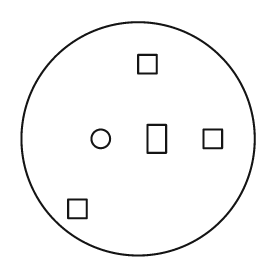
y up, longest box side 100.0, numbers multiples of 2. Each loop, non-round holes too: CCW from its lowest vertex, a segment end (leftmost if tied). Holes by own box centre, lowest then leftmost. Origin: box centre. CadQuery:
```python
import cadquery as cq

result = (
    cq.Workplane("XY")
    .moveTo(0.0, 0.0)
    .circle(50.0)
    .moveTo(-30.0, -34.0)
    .lineTo(-22.0, -34.0)
    .lineTo(-22.0, -26.0)
    .lineTo(-30.0, -26.0)
    .close()
    .moveTo(-16.0, 0.0)
    .circle(4.0)
    .moveTo(4.0, -6.0)
    .lineTo(12.0, -6.0)
    .lineTo(12.0, 6.0)
    .lineTo(4.0, 6.0)
    .close()
    .moveTo(28.0, -4.0)
    .lineTo(36.0, -4.0)
    .lineTo(36.0, 4.0)
    .lineTo(28.0, 4.0)
    .close()
    .moveTo(0.0, 28.0)
    .lineTo(8.0, 28.0)
    .lineTo(8.0, 36.0)
    .lineTo(0.0, 36.0)
    .close()
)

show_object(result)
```